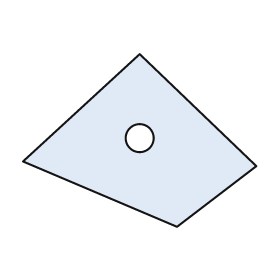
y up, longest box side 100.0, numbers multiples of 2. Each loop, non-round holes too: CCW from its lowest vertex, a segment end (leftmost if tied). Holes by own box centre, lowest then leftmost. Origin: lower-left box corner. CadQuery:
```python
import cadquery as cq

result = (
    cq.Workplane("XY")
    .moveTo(66.0, 0.0)
    .lineTo(100.0, 26.0)
    .lineTo(50.0, 74.0)
    .lineTo(0.0, 28.0)
    .close()
    .moveTo(50.0, 38.0)
    .circle(6.0)
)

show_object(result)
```